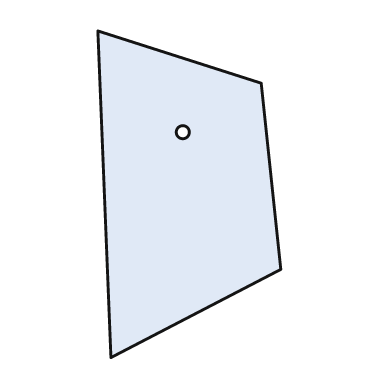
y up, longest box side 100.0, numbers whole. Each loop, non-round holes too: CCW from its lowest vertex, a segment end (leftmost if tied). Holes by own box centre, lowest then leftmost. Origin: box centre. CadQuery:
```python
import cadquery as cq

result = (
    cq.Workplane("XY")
    .moveTo(-24.0, -50.0)
    .lineTo(28.0, -23.0)
    .lineTo(22.0, 34.0)
    .lineTo(-28.0, 50.0)
    .close()
    .moveTo(-2.0, 19.0)
    .circle(2.0)
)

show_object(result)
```